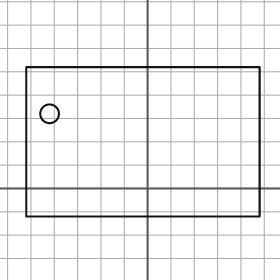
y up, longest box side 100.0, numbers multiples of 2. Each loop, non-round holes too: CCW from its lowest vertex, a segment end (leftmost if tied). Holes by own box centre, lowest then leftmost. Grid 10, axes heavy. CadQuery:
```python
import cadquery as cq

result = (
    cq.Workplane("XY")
    .moveTo(-52.0, -12.0)
    .lineTo(48.0, -12.0)
    .lineTo(48.0, 52.0)
    .lineTo(-52.0, 52.0)
    .close()
    .moveTo(-42.0, 32.0)
    .circle(4.0)
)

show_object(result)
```